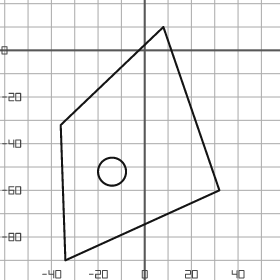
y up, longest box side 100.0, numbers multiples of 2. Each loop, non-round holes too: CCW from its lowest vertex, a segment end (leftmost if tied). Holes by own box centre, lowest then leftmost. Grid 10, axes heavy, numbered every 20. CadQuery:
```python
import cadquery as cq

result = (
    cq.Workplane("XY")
    .moveTo(-34.0, -90.0)
    .lineTo(32.0, -60.0)
    .lineTo(8.0, 10.0)
    .lineTo(-36.0, -32.0)
    .close()
    .moveTo(-14.0, -52.0)
    .circle(6.0)
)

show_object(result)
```